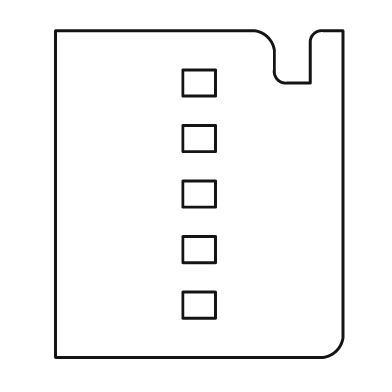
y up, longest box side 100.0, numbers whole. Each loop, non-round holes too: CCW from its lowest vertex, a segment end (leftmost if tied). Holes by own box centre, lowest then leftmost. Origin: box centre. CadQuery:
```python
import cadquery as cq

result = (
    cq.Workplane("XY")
    .moveTo(-44.0, -50.0)
    .lineTo(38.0, -50.0)
    .threePointArc((42.0, -48.0), (44.0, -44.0))
    .lineTo(44.0, 50.0)
    .lineTo(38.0, 50.0)
    .threePointArc((35.0, 49.0), (34.0, 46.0))
    .lineTo(34.0, 34.0)
    .lineTo(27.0, 34.0)
    .threePointArc((24.0, 35.0), (23.0, 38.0))
    .lineTo(23.0, 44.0)
    .threePointArc((21.0, 48.0), (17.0, 50.0))
    .lineTo(-44.0, 50.0)
    .close()
    .moveTo(-5.0, -38.0)
    .lineTo(5.0, -38.0)
    .lineTo(5.0, -30.0)
    .lineTo(-5.0, -30.0)
    .close()
    .moveTo(-5.0, -21.0)
    .lineTo(5.0, -21.0)
    .lineTo(5.0, -13.0)
    .lineTo(-5.0, -13.0)
    .close()
    .moveTo(-5.0, -4.0)
    .lineTo(5.0, -4.0)
    .lineTo(5.0, 4.0)
    .lineTo(-5.0, 4.0)
    .close()
    .moveTo(-5.0, 13.0)
    .lineTo(5.0, 13.0)
    .lineTo(5.0, 21.0)
    .lineTo(-5.0, 21.0)
    .close()
    .moveTo(-5.0, 30.0)
    .lineTo(5.0, 30.0)
    .lineTo(5.0, 38.0)
    .lineTo(-5.0, 38.0)
    .close()
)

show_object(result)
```